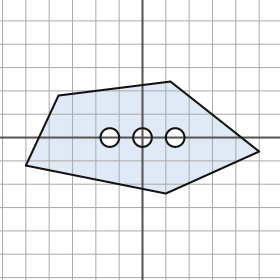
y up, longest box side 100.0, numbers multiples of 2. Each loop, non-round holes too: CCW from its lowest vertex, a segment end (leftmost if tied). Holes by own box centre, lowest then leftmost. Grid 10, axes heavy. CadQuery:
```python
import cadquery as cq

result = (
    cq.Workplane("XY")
    .moveTo(10.0, -24.0)
    .lineTo(50.0, -6.0)
    .lineTo(12.0, 24.0)
    .lineTo(-36.0, 18.0)
    .lineTo(-50.0, -12.0)
    .close()
    .moveTo(-14.0, 0.0)
    .circle(4.0)
    .moveTo(0.0, 0.0)
    .circle(4.0)
    .moveTo(14.0, 0.0)
    .circle(4.0)
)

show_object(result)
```